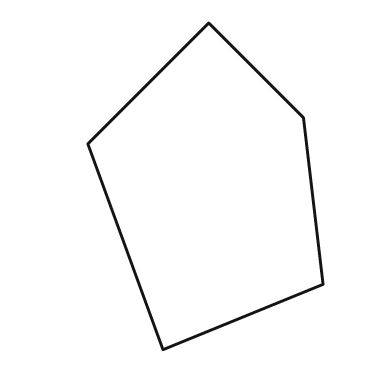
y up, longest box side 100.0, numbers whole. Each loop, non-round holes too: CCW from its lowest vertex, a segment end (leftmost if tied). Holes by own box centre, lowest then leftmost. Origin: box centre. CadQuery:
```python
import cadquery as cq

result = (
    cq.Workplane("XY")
    .moveTo(-13.0, -50.0)
    .lineTo(36.0, -30.0)
    .lineTo(30.0, 21.0)
    .lineTo(1.0, 50.0)
    .lineTo(-36.0, 13.0)
    .close()
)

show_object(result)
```